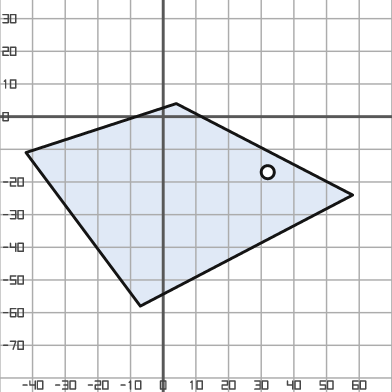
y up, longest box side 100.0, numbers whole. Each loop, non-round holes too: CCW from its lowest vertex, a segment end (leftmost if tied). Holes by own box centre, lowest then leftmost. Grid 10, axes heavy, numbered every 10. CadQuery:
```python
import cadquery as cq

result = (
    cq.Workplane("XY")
    .moveTo(-7.0, -58.0)
    .lineTo(58.0, -24.0)
    .lineTo(4.0, 4.0)
    .lineTo(-42.0, -11.0)
    .close()
    .moveTo(32.0, -17.0)
    .circle(2.0)
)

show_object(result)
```